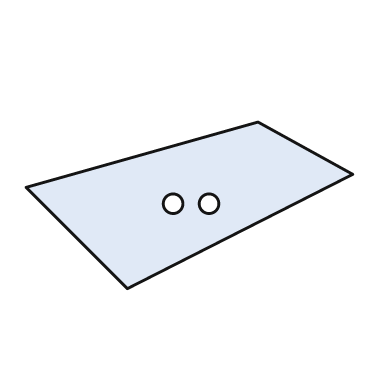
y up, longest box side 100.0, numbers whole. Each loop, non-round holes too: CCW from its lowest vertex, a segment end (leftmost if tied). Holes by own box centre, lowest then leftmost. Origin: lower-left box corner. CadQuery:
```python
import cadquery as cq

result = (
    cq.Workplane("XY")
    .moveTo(31.0, 0.0)
    .lineTo(100.0, 35.0)
    .lineTo(71.0, 51.0)
    .lineTo(0.0, 31.0)
    .close()
    .moveTo(45.0, 26.0)
    .circle(3.0)
    .moveTo(56.0, 26.0)
    .circle(3.0)
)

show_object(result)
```